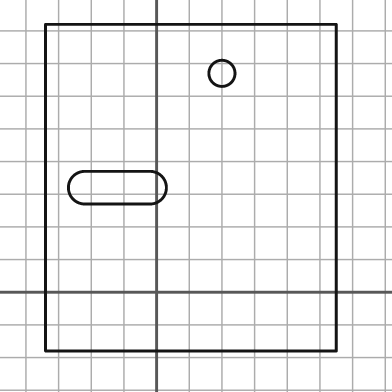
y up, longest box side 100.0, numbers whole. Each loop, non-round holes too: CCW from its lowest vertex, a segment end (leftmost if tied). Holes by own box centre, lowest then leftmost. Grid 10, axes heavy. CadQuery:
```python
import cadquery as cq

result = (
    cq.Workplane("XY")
    .moveTo(-34.0, -18.0)
    .lineTo(55.0, -18.0)
    .lineTo(55.0, 82.0)
    .lineTo(-34.0, 82.0)
    .close()
    .moveTo(-22.0, 27.0)
    .lineTo(-2.0, 27.0)
    .threePointArc((3.0, 32.0), (-2.0, 37.0))
    .lineTo(-22.0, 37.0)
    .threePointArc((-27.0, 32.0), (-22.0, 27.0))
    .close()
    .moveTo(20.0, 67.0)
    .circle(4.0)
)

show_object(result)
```